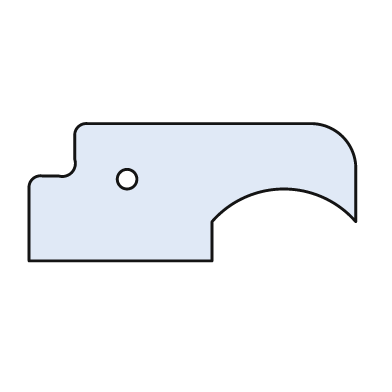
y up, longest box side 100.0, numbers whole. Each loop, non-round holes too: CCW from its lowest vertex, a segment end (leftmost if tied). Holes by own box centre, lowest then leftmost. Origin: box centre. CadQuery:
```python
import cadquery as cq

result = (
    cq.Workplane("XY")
    .moveTo(-50.0, -21.0)
    .lineTo(6.0, -21.0)
    .lineTo(6.0, -9.0)
    .threePointArc((28.0, 1.0), (50.0, -9.0))
    .lineTo(50.0, 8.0)
    .threePointArc((46.0, 17.0), (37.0, 21.0))
    .lineTo(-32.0, 21.0)
    .threePointArc((-35.0, 20.0), (-36.0, 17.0))
    .lineTo(-36.0, 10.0)
    .threePointArc((-37.0, 6.0), (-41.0, 5.0))
    .lineTo(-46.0, 5.0)
    .threePointArc((-49.0, 4.0), (-50.0, 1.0))
    .close()
    .moveTo(-20.0, 4.0)
    .circle(3.0)
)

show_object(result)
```